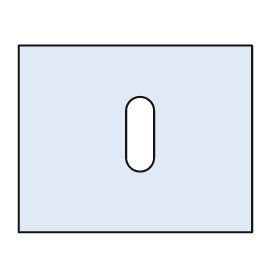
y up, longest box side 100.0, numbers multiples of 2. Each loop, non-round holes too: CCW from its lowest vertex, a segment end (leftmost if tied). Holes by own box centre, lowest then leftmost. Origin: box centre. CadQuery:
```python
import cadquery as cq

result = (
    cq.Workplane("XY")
    .moveTo(-50.0, -40.0)
    .lineTo(50.0, -40.0)
    .lineTo(50.0, 40.0)
    .lineTo(-50.0, 40.0)
    .close()
    .moveTo(-4.0, -8.0)
    .threePointArc((2.0, -14.0), (8.0, -8.0))
    .lineTo(8.0, 12.0)
    .threePointArc((2.0, 18.0), (-4.0, 12.0))
    .close()
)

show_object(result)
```